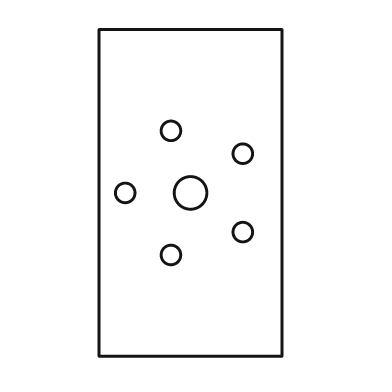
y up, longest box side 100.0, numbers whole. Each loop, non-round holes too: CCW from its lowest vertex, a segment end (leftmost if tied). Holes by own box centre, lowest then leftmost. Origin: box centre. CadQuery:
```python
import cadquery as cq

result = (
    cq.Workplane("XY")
    .moveTo(-28.0, -50.0)
    .lineTo(28.0, -50.0)
    .lineTo(28.0, 50.0)
    .lineTo(-28.0, 50.0)
    .close()
    .moveTo(-6.0, -19.0)
    .circle(3.0)
    .moveTo(16.0, -12.0)
    .circle(3.0)
    .moveTo(-20.0, 0.0)
    .circle(3.0)
    .moveTo(0.0, 0.0)
    .circle(5.0)
    .moveTo(16.0, 12.0)
    .circle(3.0)
    .moveTo(-6.0, 19.0)
    .circle(3.0)
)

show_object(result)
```